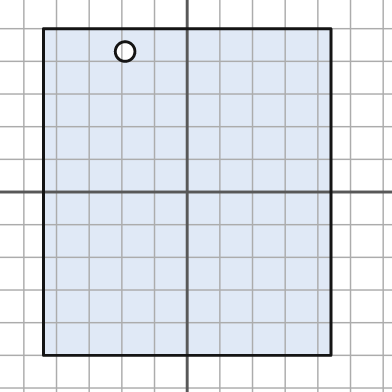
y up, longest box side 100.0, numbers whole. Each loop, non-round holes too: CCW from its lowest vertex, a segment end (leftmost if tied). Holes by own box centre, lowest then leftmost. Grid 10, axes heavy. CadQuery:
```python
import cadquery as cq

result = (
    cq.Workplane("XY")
    .moveTo(-44.0, -50.0)
    .lineTo(44.0, -50.0)
    .lineTo(44.0, 50.0)
    .lineTo(-44.0, 50.0)
    .close()
    .moveTo(-19.0, 43.0)
    .circle(3.0)
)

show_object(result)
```